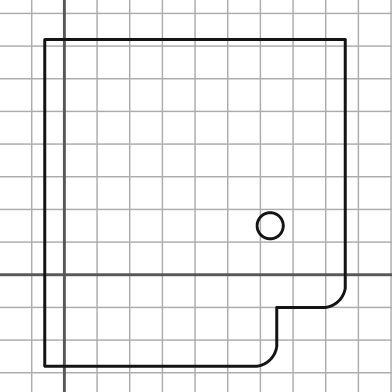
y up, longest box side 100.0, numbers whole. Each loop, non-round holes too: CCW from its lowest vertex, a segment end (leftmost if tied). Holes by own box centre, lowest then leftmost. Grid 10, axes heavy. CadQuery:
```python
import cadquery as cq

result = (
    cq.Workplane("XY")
    .moveTo(-6.0, -28.0)
    .lineTo(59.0, -28.0)
    .threePointArc((63.0, -26.0), (65.0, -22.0))
    .lineTo(65.0, -10.0)
    .lineTo(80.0, -10.0)
    .threePointArc((84.0, -8.0), (86.0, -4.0))
    .lineTo(86.0, 72.0)
    .lineTo(-6.0, 72.0)
    .close()
    .moveTo(63.0, 15.0)
    .circle(4.0)
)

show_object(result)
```